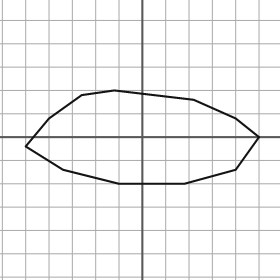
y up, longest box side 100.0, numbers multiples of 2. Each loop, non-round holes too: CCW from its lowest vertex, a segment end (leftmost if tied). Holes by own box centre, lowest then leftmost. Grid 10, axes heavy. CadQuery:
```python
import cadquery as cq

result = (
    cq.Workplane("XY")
    .moveTo(-10.0, -20.0)
    .lineTo(18.0, -20.0)
    .lineTo(40.0, -14.0)
    .lineTo(50.0, 0.0)
    .lineTo(40.0, 8.0)
    .lineTo(22.0, 16.0)
    .lineTo(-12.0, 20.0)
    .lineTo(-26.0, 18.0)
    .lineTo(-40.0, 8.0)
    .lineTo(-50.0, -4.0)
    .lineTo(-34.0, -14.0)
    .close()
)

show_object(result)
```